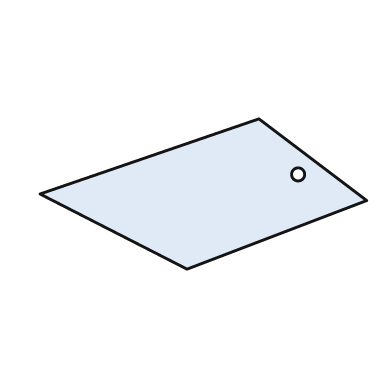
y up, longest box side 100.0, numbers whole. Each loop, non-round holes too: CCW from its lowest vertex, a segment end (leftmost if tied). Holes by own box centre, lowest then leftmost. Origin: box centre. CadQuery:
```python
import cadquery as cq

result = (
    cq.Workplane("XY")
    .moveTo(-5.0, -23.0)
    .lineTo(50.0, -2.0)
    .lineTo(17.0, 23.0)
    .lineTo(-50.0, 0.0)
    .close()
    .moveTo(29.0, 6.0)
    .circle(2.0)
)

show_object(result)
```